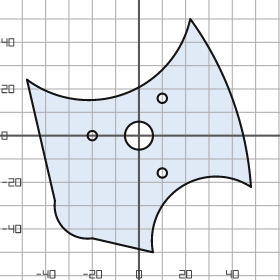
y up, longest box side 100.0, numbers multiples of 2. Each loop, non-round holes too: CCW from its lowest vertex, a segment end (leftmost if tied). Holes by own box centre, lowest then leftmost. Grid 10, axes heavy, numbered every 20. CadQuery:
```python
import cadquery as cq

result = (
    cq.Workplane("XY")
    .moveTo(6.0, -50.0)
    .threePointArc((18.0, -22.0), (48.0, -22.0))
    .threePointArc((40.0, 16.0), (22.0, 50.0))
    .threePointArc((-6.0, 18.0), (-48.0, 24.0))
    .lineTo(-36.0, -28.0)
    .threePointArc((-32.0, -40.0), (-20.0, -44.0))
    .close()
    .moveTo(10.0, -16.0)
    .circle(2.0)
    .moveTo(-20.0, 0.0)
    .circle(2.0)
    .moveTo(0.0, 0.0)
    .circle(6.0)
    .moveTo(10.0, 16.0)
    .circle(2.0)
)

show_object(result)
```